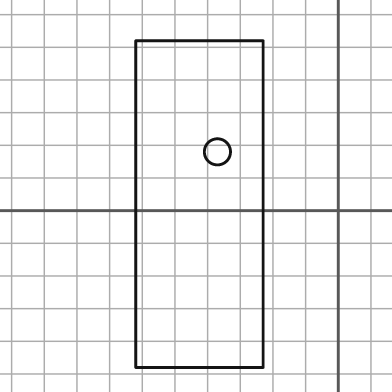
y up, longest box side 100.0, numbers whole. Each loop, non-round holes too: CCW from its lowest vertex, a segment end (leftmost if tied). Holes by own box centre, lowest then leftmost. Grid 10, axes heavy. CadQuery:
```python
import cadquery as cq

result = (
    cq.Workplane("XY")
    .moveTo(-62.0, -48.0)
    .lineTo(-23.0, -48.0)
    .lineTo(-23.0, 52.0)
    .lineTo(-62.0, 52.0)
    .close()
    .moveTo(-37.0, 18.0)
    .circle(4.0)
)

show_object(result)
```